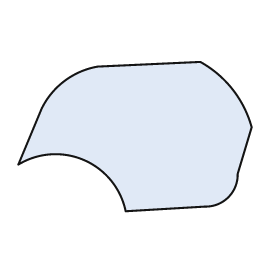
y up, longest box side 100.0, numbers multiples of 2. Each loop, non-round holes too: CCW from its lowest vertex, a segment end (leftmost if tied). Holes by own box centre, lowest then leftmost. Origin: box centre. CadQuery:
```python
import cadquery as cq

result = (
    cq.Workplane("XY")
    .moveTo(-4.0, -32.0)
    .lineTo(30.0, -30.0)
    .threePointArc((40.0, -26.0), (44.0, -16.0))
    .lineTo(50.0, 4.0)
    .threePointArc((42.0, 20.0), (28.0, 32.0))
    .lineTo(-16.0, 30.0)
    .threePointArc((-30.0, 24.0), (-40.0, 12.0))
    .lineTo(-50.0, -12.0)
    .threePointArc((-22.0, -10.0), (-4.0, -32.0))
    .close()
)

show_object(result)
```